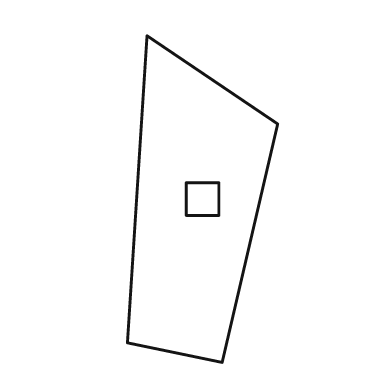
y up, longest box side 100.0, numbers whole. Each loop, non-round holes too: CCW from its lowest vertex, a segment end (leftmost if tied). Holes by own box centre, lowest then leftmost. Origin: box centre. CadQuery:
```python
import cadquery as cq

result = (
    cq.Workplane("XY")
    .moveTo(6.0, -50.0)
    .lineTo(23.0, 23.0)
    .lineTo(-17.0, 50.0)
    .lineTo(-23.0, -44.0)
    .close()
    .moveTo(-5.0, -5.0)
    .lineTo(5.0, -5.0)
    .lineTo(5.0, 5.0)
    .lineTo(-5.0, 5.0)
    .close()
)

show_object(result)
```